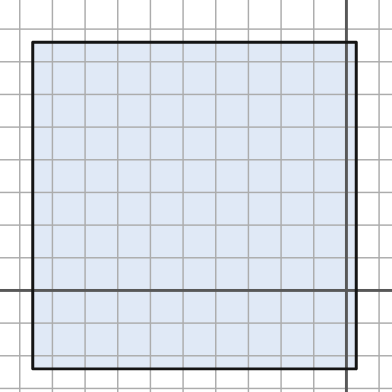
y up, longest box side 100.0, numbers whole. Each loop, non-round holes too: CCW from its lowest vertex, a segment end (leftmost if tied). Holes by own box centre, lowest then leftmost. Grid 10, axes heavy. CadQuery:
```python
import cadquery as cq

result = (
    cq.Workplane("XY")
    .moveTo(-96.0, -24.0)
    .lineTo(3.0, -24.0)
    .lineTo(3.0, 76.0)
    .lineTo(-96.0, 76.0)
    .close()
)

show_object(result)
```